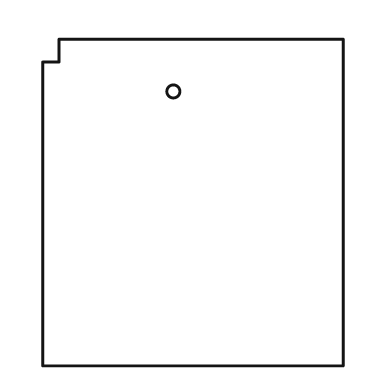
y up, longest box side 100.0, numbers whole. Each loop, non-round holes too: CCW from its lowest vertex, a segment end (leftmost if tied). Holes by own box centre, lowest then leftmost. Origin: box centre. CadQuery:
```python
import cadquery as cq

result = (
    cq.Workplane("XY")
    .moveTo(-46.0, -50.0)
    .lineTo(46.0, -50.0)
    .lineTo(46.0, 50.0)
    .lineTo(-41.0, 50.0)
    .lineTo(-41.0, 43.0)
    .lineTo(-46.0, 43.0)
    .close()
    .moveTo(-6.0, 34.0)
    .circle(2.0)
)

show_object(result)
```